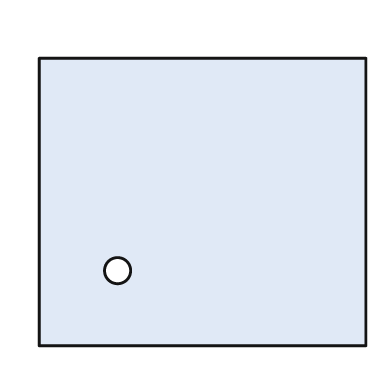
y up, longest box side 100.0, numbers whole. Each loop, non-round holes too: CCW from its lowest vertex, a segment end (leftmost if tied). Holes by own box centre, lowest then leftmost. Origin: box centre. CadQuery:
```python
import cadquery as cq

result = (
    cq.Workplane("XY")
    .moveTo(-50.0, -44.0)
    .lineTo(50.0, -44.0)
    .lineTo(50.0, 44.0)
    .lineTo(-50.0, 44.0)
    .close()
    .moveTo(-26.0, -21.0)
    .circle(4.0)
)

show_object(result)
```